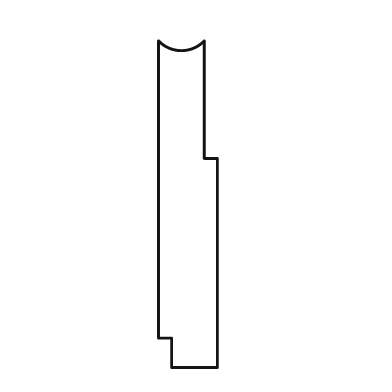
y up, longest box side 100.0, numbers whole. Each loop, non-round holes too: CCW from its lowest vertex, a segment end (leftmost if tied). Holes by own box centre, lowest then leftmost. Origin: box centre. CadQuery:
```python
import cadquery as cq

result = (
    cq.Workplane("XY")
    .moveTo(-5.0, -50.0)
    .lineTo(9.0, -50.0)
    .lineTo(9.0, 14.0)
    .lineTo(5.0, 14.0)
    .lineTo(5.0, 50.0)
    .threePointArc((-2.0, 47.0), (-9.0, 50.0))
    .lineTo(-9.0, -41.0)
    .lineTo(-5.0, -41.0)
    .close()
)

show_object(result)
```